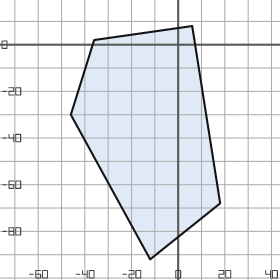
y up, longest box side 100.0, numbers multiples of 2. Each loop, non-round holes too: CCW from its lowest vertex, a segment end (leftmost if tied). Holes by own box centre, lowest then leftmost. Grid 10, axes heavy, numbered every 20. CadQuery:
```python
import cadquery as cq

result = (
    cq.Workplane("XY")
    .moveTo(-12.0, -92.0)
    .lineTo(18.0, -68.0)
    .lineTo(6.0, 8.0)
    .lineTo(-36.0, 2.0)
    .lineTo(-46.0, -30.0)
    .close()
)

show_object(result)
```